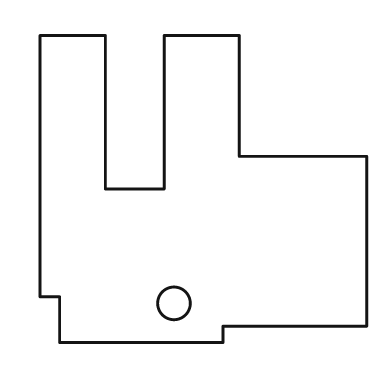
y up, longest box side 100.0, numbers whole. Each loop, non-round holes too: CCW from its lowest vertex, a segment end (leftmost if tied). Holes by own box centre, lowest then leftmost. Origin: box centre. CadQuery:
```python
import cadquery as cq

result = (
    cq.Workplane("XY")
    .moveTo(-44.0, -47.0)
    .lineTo(6.0, -47.0)
    .lineTo(6.0, -42.0)
    .lineTo(50.0, -42.0)
    .lineTo(50.0, 10.0)
    .lineTo(11.0, 10.0)
    .lineTo(11.0, 47.0)
    .lineTo(-12.0, 47.0)
    .lineTo(-12.0, 0.0)
    .lineTo(-30.0, 0.0)
    .lineTo(-30.0, 47.0)
    .lineTo(-50.0, 47.0)
    .lineTo(-50.0, -33.0)
    .lineTo(-44.0, -33.0)
    .close()
    .moveTo(-9.0, -35.0)
    .circle(5.0)
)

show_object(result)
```